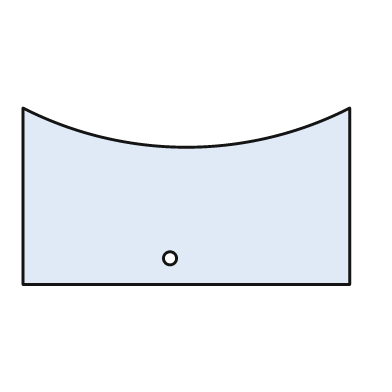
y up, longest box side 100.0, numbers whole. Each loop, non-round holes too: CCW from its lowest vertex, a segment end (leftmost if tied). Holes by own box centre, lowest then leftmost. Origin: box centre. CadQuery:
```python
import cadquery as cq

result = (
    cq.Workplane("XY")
    .moveTo(-50.0, -27.0)
    .lineTo(50.0, -27.0)
    .lineTo(50.0, 27.0)
    .threePointArc((0.0, 15.0), (-50.0, 27.0))
    .close()
    .moveTo(-5.0, -19.0)
    .circle(2.0)
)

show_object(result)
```